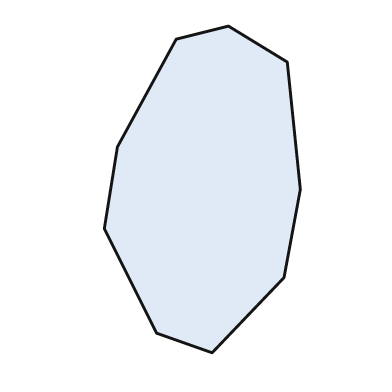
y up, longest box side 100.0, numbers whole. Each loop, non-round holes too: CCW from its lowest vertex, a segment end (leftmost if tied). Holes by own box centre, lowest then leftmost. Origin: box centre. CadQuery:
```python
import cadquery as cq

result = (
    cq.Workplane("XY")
    .moveTo(3.0, -50.0)
    .lineTo(25.0, -27.0)
    .lineTo(30.0, 0.0)
    .lineTo(26.0, 39.0)
    .lineTo(8.0, 50.0)
    .lineTo(-8.0, 46.0)
    .lineTo(-26.0, 13.0)
    .lineTo(-30.0, -12.0)
    .lineTo(-14.0, -44.0)
    .close()
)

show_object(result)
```